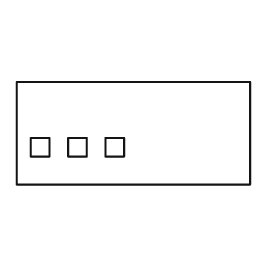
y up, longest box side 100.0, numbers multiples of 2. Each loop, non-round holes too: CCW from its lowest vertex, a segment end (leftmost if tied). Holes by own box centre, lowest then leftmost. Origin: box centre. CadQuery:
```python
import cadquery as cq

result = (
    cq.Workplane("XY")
    .moveTo(-50.0, -22.0)
    .lineTo(50.0, -22.0)
    .lineTo(50.0, 22.0)
    .lineTo(-50.0, 22.0)
    .close()
    .moveTo(-44.0, -10.0)
    .lineTo(-36.0, -10.0)
    .lineTo(-36.0, -2.0)
    .lineTo(-44.0, -2.0)
    .close()
    .moveTo(-28.0, -10.0)
    .lineTo(-20.0, -10.0)
    .lineTo(-20.0, -2.0)
    .lineTo(-28.0, -2.0)
    .close()
    .moveTo(-12.0, -10.0)
    .lineTo(-4.0, -10.0)
    .lineTo(-4.0, -2.0)
    .lineTo(-12.0, -2.0)
    .close()
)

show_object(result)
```